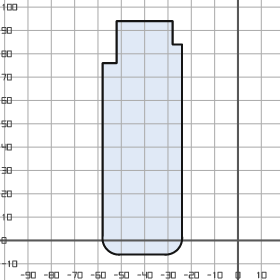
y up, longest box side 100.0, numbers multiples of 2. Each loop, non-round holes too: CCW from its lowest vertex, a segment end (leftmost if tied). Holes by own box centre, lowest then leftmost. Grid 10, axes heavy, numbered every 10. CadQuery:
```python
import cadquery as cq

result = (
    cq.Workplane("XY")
    .moveTo(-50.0, -6.0)
    .lineTo(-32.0, -6.0)
    .threePointArc((-26.0, -4.0), (-24.0, 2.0))
    .lineTo(-24.0, 84.0)
    .lineTo(-28.0, 84.0)
    .lineTo(-28.0, 94.0)
    .lineTo(-52.0, 94.0)
    .lineTo(-52.0, 76.0)
    .lineTo(-58.0, 76.0)
    .lineTo(-58.0, 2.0)
    .threePointArc((-56.0, -4.0), (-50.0, -6.0))
    .close()
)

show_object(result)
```